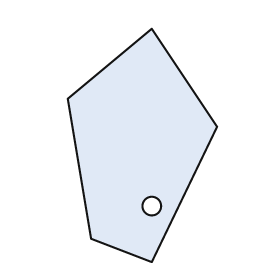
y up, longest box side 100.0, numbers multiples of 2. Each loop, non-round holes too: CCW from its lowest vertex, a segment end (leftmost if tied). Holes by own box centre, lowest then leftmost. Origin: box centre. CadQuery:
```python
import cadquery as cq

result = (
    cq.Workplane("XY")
    .moveTo(4.0, -50.0)
    .lineTo(32.0, 8.0)
    .lineTo(4.0, 50.0)
    .lineTo(-32.0, 20.0)
    .lineTo(-22.0, -40.0)
    .close()
    .moveTo(4.0, -26.0)
    .circle(4.0)
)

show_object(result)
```